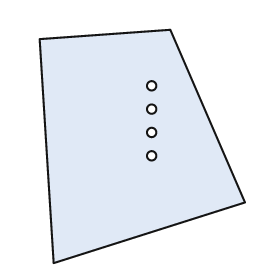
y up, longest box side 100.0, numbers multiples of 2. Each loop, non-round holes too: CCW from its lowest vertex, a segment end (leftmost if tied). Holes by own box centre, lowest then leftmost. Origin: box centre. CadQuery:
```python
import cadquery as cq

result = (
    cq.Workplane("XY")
    .moveTo(-38.0, -50.0)
    .lineTo(44.0, -24.0)
    .lineTo(12.0, 50.0)
    .lineTo(-44.0, 46.0)
    .close()
    .moveTo(4.0, -4.0)
    .circle(2.0)
    .moveTo(4.0, 6.0)
    .circle(2.0)
    .moveTo(4.0, 16.0)
    .circle(2.0)
    .moveTo(4.0, 26.0)
    .circle(2.0)
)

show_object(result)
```